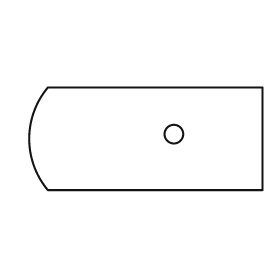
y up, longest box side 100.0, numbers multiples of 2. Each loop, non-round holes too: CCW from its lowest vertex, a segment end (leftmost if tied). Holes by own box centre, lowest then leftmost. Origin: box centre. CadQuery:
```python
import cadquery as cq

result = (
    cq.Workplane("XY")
    .moveTo(-42.0, -22.0)
    .lineTo(50.0, -22.0)
    .lineTo(50.0, 22.0)
    .lineTo(-42.0, 22.0)
    .threePointArc((-50.0, 0.0), (-42.0, -22.0))
    .close()
    .moveTo(12.0, 2.0)
    .circle(4.0)
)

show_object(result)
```